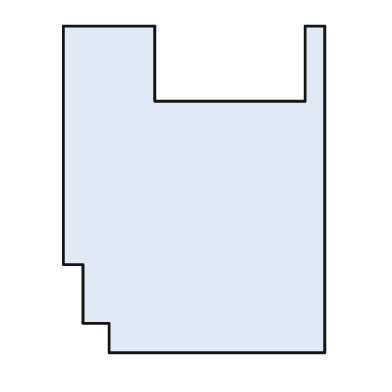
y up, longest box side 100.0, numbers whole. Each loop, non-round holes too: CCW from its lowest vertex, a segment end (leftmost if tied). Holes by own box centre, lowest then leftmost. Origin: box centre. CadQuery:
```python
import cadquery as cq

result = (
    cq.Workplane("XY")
    .moveTo(-26.0, -50.0)
    .lineTo(40.0, -50.0)
    .lineTo(40.0, 50.0)
    .lineTo(34.0, 50.0)
    .lineTo(34.0, 27.0)
    .lineTo(-12.0, 27.0)
    .lineTo(-12.0, 50.0)
    .lineTo(-40.0, 50.0)
    .lineTo(-40.0, -23.0)
    .lineTo(-34.0, -23.0)
    .lineTo(-34.0, -41.0)
    .lineTo(-26.0, -41.0)
    .close()
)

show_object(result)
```